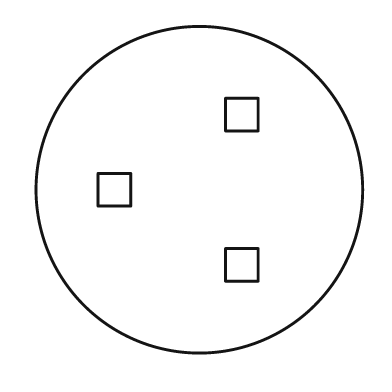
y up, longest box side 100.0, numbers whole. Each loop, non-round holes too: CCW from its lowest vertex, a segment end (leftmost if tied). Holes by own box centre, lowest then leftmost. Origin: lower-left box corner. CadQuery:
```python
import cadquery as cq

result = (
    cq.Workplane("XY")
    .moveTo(50.0, 50.0)
    .circle(50.0)
    .moveTo(58.0, 22.0)
    .lineTo(68.0, 22.0)
    .lineTo(68.0, 32.0)
    .lineTo(58.0, 32.0)
    .close()
    .moveTo(19.0, 45.0)
    .lineTo(29.0, 45.0)
    .lineTo(29.0, 55.0)
    .lineTo(19.0, 55.0)
    .close()
    .moveTo(58.0, 68.0)
    .lineTo(68.0, 68.0)
    .lineTo(68.0, 78.0)
    .lineTo(58.0, 78.0)
    .close()
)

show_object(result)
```